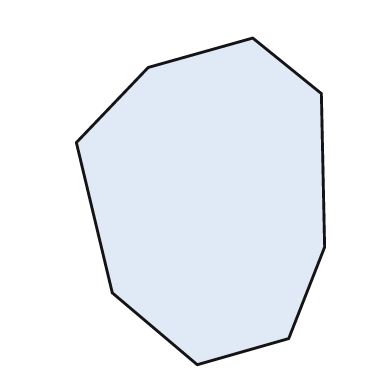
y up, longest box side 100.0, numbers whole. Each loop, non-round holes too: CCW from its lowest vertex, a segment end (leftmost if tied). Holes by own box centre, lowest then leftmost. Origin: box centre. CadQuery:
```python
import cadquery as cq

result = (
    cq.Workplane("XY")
    .moveTo(-1.0, -50.0)
    .lineTo(27.0, -42.0)
    .lineTo(38.0, -14.0)
    .lineTo(37.0, 33.0)
    .lineTo(16.0, 50.0)
    .lineTo(-16.0, 41.0)
    .lineTo(-38.0, 18.0)
    .lineTo(-27.0, -28.0)
    .close()
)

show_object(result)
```